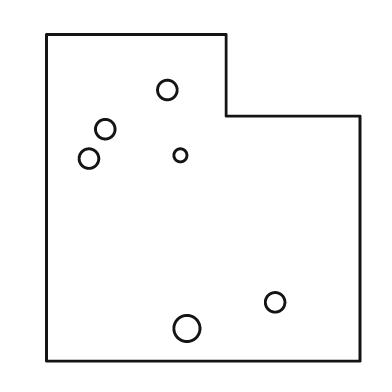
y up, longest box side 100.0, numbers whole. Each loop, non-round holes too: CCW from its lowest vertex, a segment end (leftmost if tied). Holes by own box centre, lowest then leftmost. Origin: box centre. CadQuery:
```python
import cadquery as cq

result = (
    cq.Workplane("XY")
    .moveTo(-48.0, -50.0)
    .lineTo(48.0, -50.0)
    .lineTo(48.0, 25.0)
    .lineTo(7.0, 25.0)
    .lineTo(7.0, 50.0)
    .lineTo(-48.0, 50.0)
    .close()
    .moveTo(-5.0, -40.0)
    .circle(4.0)
    .moveTo(22.0, -32.0)
    .circle(3.0)
    .moveTo(-35.0, 12.0)
    .circle(3.0)
    .moveTo(-7.0, 13.0)
    .circle(2.0)
    .moveTo(-30.0, 21.0)
    .circle(3.0)
    .moveTo(-11.0, 33.0)
    .circle(3.0)
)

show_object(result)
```